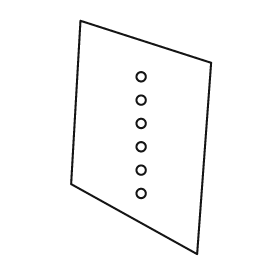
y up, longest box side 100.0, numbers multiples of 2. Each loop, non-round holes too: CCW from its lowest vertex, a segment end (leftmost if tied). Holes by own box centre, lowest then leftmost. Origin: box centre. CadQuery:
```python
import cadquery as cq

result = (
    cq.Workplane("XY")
    .moveTo(24.0, -50.0)
    .lineTo(30.0, 32.0)
    .lineTo(-26.0, 50.0)
    .lineTo(-30.0, -20.0)
    .close()
    .moveTo(0.0, -24.0)
    .circle(2.0)
    .moveTo(0.0, -14.0)
    .circle(2.0)
    .moveTo(0.0, -4.0)
    .circle(2.0)
    .moveTo(0.0, 6.0)
    .circle(2.0)
    .moveTo(0.0, 16.0)
    .circle(2.0)
    .moveTo(0.0, 26.0)
    .circle(2.0)
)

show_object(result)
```